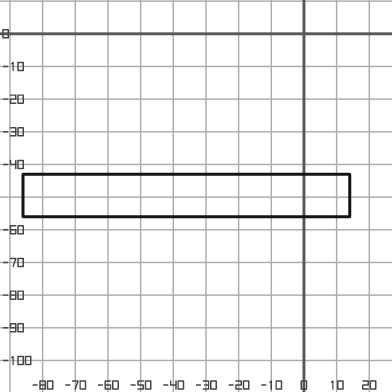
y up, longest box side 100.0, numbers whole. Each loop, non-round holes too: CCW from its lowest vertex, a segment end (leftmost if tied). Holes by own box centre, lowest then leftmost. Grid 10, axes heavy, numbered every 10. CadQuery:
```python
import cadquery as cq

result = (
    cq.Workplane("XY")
    .moveTo(-86.0, -56.0)
    .lineTo(14.0, -56.0)
    .lineTo(14.0, -43.0)
    .lineTo(-86.0, -43.0)
    .close()
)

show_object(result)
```